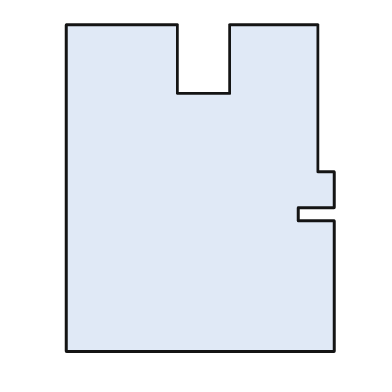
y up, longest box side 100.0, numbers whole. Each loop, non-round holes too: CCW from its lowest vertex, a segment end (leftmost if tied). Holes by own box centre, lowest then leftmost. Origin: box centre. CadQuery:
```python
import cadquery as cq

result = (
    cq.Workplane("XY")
    .moveTo(-41.0, -50.0)
    .lineTo(41.0, -50.0)
    .lineTo(41.0, -10.0)
    .lineTo(30.0, -10.0)
    .lineTo(30.0, -6.0)
    .lineTo(41.0, -6.0)
    .lineTo(41.0, 5.0)
    .lineTo(36.0, 5.0)
    .lineTo(36.0, 50.0)
    .lineTo(9.0, 50.0)
    .lineTo(9.0, 29.0)
    .lineTo(-7.0, 29.0)
    .lineTo(-7.0, 50.0)
    .lineTo(-41.0, 50.0)
    .close()
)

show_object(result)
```